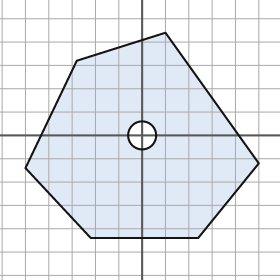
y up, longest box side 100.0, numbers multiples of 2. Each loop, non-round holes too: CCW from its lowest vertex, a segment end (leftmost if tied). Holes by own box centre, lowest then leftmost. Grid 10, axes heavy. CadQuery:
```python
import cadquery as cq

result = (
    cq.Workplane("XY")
    .moveTo(-22.0, -44.0)
    .lineTo(24.0, -44.0)
    .lineTo(50.0, -12.0)
    .lineTo(10.0, 44.0)
    .lineTo(-28.0, 32.0)
    .lineTo(-50.0, -14.0)
    .close()
    .moveTo(0.0, 0.0)
    .circle(6.0)
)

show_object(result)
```